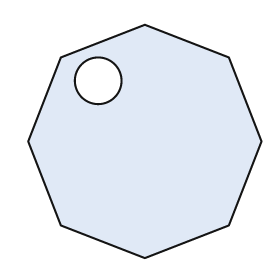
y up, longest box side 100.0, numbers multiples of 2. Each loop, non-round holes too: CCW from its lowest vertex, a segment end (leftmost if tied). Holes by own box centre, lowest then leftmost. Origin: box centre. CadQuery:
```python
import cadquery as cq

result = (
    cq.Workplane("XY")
    .moveTo(0.0, -50.0)
    .lineTo(36.0, -36.0)
    .lineTo(50.0, 0.0)
    .lineTo(36.0, 36.0)
    .lineTo(0.0, 50.0)
    .lineTo(-36.0, 36.0)
    .lineTo(-50.0, 0.0)
    .lineTo(-36.0, -36.0)
    .close()
    .moveTo(-20.0, 26.0)
    .circle(10.0)
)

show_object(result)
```